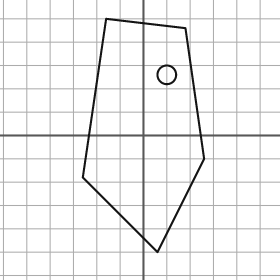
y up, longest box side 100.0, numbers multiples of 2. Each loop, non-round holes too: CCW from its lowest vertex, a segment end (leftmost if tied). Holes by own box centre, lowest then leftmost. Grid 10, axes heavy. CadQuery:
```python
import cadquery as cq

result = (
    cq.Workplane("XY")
    .moveTo(6.0, -50.0)
    .lineTo(26.0, -10.0)
    .lineTo(18.0, 46.0)
    .lineTo(-16.0, 50.0)
    .lineTo(-26.0, -18.0)
    .close()
    .moveTo(10.0, 26.0)
    .circle(4.0)
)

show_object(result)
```